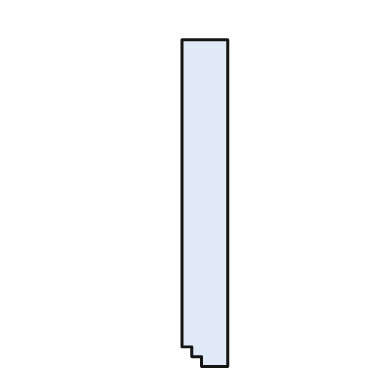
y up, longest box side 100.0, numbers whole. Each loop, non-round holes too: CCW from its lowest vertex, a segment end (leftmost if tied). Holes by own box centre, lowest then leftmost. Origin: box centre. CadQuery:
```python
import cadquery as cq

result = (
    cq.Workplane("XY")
    .moveTo(-1.0, -50.0)
    .lineTo(7.0, -50.0)
    .lineTo(7.0, 50.0)
    .lineTo(-7.0, 50.0)
    .lineTo(-7.0, -44.0)
    .lineTo(-4.0, -44.0)
    .lineTo(-4.0, -47.0)
    .lineTo(-1.0, -47.0)
    .close()
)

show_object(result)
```